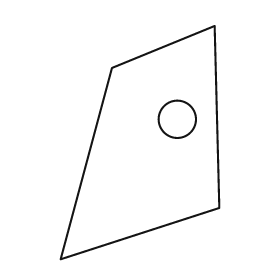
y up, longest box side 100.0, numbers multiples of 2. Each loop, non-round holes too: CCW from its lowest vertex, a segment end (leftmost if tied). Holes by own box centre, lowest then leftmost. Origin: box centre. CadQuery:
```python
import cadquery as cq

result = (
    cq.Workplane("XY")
    .moveTo(-34.0, -50.0)
    .lineTo(34.0, -28.0)
    .lineTo(32.0, 50.0)
    .lineTo(-12.0, 32.0)
    .close()
    .moveTo(16.0, 10.0)
    .circle(8.0)
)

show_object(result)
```